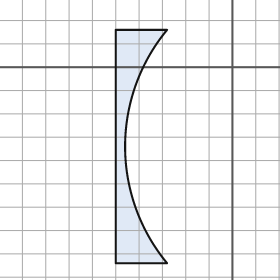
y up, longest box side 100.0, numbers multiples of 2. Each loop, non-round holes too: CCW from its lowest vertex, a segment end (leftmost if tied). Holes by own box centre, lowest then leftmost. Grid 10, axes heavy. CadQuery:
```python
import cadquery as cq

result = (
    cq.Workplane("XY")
    .moveTo(-50.0, -84.0)
    .lineTo(-28.0, -84.0)
    .threePointArc((-46.0, -34.0), (-28.0, 16.0))
    .lineTo(-50.0, 16.0)
    .close()
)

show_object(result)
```